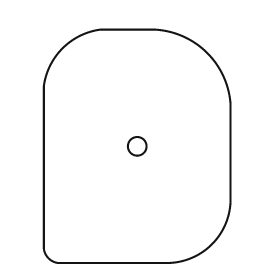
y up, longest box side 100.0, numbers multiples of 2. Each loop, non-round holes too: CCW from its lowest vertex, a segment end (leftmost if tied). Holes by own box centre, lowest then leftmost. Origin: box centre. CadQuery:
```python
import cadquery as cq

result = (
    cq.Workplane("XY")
    .moveTo(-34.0, -50.0)
    .lineTo(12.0, -50.0)
    .threePointArc((32.0, -42.0), (40.0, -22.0))
    .lineTo(40.0, 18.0)
    .threePointArc((30.0, 40.0), (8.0, 50.0))
    .lineTo(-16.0, 50.0)
    .threePointArc((-32.0, 42.0), (-40.0, 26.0))
    .lineTo(-40.0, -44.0)
    .threePointArc((-38.0, -48.0), (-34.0, -50.0))
    .close()
    .moveTo(0.0, 0.0)
    .circle(4.0)
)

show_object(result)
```